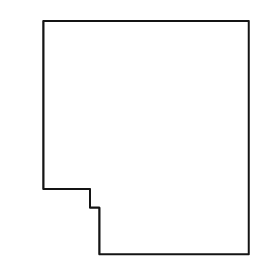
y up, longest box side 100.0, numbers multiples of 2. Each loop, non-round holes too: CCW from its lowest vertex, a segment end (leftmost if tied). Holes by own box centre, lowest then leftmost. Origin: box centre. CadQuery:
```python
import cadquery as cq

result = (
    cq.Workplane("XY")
    .moveTo(-20.0, -50.0)
    .lineTo(44.0, -50.0)
    .lineTo(44.0, 50.0)
    .lineTo(-44.0, 50.0)
    .lineTo(-44.0, -22.0)
    .lineTo(-24.0, -22.0)
    .lineTo(-24.0, -30.0)
    .lineTo(-20.0, -30.0)
    .close()
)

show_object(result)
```